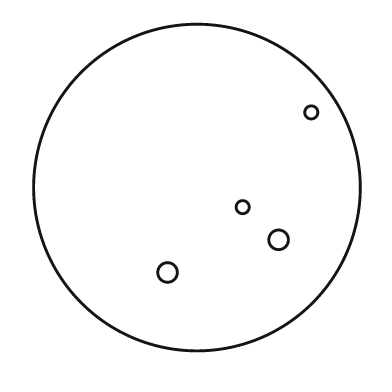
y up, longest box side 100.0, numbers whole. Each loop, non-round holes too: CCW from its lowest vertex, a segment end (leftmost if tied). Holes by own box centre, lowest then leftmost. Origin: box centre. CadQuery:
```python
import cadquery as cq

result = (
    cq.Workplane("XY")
    .moveTo(0.0, 0.0)
    .circle(50.0)
    .moveTo(-9.0, -26.0)
    .circle(3.0)
    .moveTo(25.0, -16.0)
    .circle(3.0)
    .moveTo(14.0, -6.0)
    .circle(2.0)
    .moveTo(35.0, 23.0)
    .circle(2.0)
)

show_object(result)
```